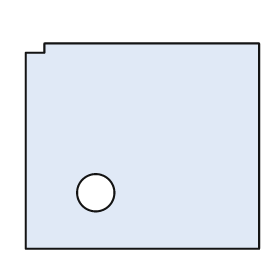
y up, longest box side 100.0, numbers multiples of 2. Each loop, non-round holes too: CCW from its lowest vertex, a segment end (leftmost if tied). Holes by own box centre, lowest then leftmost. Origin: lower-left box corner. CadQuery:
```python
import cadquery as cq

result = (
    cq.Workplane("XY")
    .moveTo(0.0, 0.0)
    .lineTo(100.0, 0.0)
    .lineTo(100.0, 88.0)
    .lineTo(8.0, 88.0)
    .lineTo(8.0, 84.0)
    .lineTo(0.0, 84.0)
    .close()
    .moveTo(30.0, 24.0)
    .circle(8.0)
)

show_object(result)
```